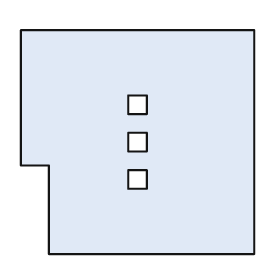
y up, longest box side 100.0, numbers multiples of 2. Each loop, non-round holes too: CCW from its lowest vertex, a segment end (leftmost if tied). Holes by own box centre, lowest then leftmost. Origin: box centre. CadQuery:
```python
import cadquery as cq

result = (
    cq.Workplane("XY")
    .moveTo(-38.0, -48.0)
    .lineTo(50.0, -48.0)
    .lineTo(50.0, 48.0)
    .lineTo(-50.0, 48.0)
    .lineTo(-50.0, -10.0)
    .lineTo(-38.0, -10.0)
    .close()
    .moveTo(-4.0, -20.0)
    .lineTo(4.0, -20.0)
    .lineTo(4.0, -12.0)
    .lineTo(-4.0, -12.0)
    .close()
    .moveTo(-4.0, -4.0)
    .lineTo(4.0, -4.0)
    .lineTo(4.0, 4.0)
    .lineTo(-4.0, 4.0)
    .close()
    .moveTo(-4.0, 12.0)
    .lineTo(4.0, 12.0)
    .lineTo(4.0, 20.0)
    .lineTo(-4.0, 20.0)
    .close()
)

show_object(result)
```